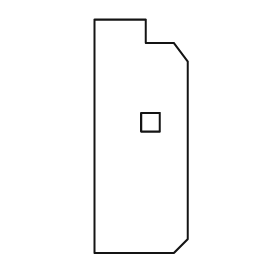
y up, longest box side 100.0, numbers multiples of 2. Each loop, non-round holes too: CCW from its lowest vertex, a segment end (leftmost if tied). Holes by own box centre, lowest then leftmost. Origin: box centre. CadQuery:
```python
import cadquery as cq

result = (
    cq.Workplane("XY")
    .moveTo(-20.0, -50.0)
    .lineTo(14.0, -50.0)
    .lineTo(20.0, -44.0)
    .lineTo(20.0, 32.0)
    .lineTo(14.0, 40.0)
    .lineTo(2.0, 40.0)
    .lineTo(2.0, 50.0)
    .lineTo(-20.0, 50.0)
    .close()
    .moveTo(0.0, 2.0)
    .lineTo(8.0, 2.0)
    .lineTo(8.0, 10.0)
    .lineTo(0.0, 10.0)
    .close()
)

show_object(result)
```